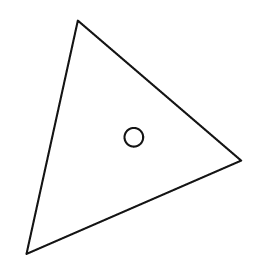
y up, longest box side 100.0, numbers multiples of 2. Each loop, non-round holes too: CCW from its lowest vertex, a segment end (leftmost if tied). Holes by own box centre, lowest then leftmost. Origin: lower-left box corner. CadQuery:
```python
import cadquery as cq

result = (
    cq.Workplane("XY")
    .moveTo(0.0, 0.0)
    .lineTo(92.0, 40.0)
    .lineTo(22.0, 100.0)
    .close()
    .moveTo(46.0, 50.0)
    .circle(4.0)
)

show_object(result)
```